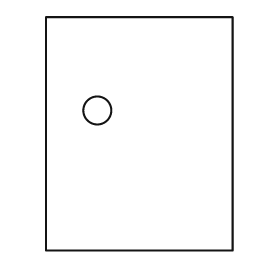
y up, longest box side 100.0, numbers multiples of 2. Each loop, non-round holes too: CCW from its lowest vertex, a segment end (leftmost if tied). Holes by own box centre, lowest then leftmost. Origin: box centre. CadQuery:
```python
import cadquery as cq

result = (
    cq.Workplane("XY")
    .moveTo(-40.0, -50.0)
    .lineTo(40.0, -50.0)
    .lineTo(40.0, 50.0)
    .lineTo(-40.0, 50.0)
    .close()
    .moveTo(-18.0, 10.0)
    .circle(6.0)
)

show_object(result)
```